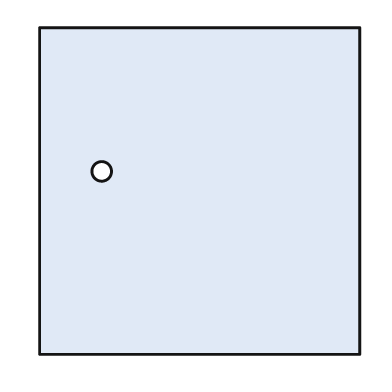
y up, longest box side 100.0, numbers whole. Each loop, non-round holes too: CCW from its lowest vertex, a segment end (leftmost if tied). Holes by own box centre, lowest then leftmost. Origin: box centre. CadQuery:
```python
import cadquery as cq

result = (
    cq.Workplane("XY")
    .moveTo(-49.0, -50.0)
    .lineTo(49.0, -50.0)
    .lineTo(49.0, 50.0)
    .lineTo(-49.0, 50.0)
    .close()
    .moveTo(-30.0, 6.0)
    .circle(3.0)
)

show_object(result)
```